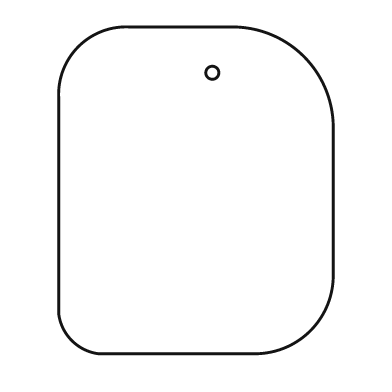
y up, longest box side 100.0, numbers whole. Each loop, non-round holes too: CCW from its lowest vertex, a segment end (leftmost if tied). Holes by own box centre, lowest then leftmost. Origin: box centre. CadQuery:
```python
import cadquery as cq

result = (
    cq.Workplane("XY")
    .moveTo(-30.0, -50.0)
    .lineTo(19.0, -50.0)
    .threePointArc((35.0, -43.0), (42.0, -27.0))
    .lineTo(42.0, 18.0)
    .threePointArc((33.0, 41.0), (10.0, 50.0))
    .lineTo(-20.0, 50.0)
    .threePointArc((-36.0, 44.0), (-42.0, 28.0))
    .lineTo(-42.0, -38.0)
    .threePointArc((-38.0, -46.0), (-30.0, -50.0))
    .close()
    .moveTo(5.0, 36.0)
    .circle(2.0)
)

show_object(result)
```